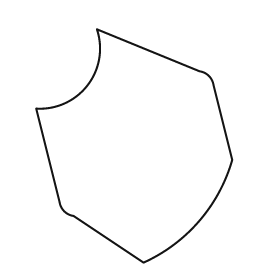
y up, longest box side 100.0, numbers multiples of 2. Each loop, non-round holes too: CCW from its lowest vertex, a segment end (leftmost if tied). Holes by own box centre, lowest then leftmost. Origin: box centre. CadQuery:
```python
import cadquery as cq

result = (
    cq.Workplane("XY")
    .moveTo(4.0, -50.0)
    .threePointArc((28.0, -32.0), (42.0, -6.0))
    .lineTo(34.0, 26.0)
    .threePointArc((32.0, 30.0), (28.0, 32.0))
    .lineTo(-16.0, 50.0)
    .threePointArc((-20.0, 26.0), (-42.0, 16.0))
    .lineTo(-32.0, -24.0)
    .threePointArc((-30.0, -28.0), (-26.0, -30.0))
    .close()
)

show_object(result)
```